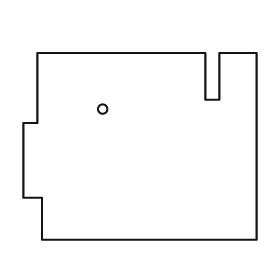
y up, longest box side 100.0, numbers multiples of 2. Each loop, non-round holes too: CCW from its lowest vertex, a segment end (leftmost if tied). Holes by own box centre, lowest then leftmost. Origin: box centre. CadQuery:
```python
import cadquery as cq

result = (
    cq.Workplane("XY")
    .moveTo(-42.0, -40.0)
    .lineTo(50.0, -40.0)
    .lineTo(50.0, 40.0)
    .lineTo(34.0, 40.0)
    .lineTo(34.0, 20.0)
    .lineTo(28.0, 20.0)
    .lineTo(28.0, 40.0)
    .lineTo(-44.0, 40.0)
    .lineTo(-44.0, 10.0)
    .lineTo(-50.0, 10.0)
    .lineTo(-50.0, -22.0)
    .lineTo(-42.0, -22.0)
    .close()
    .moveTo(-16.0, 16.0)
    .circle(2.0)
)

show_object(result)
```